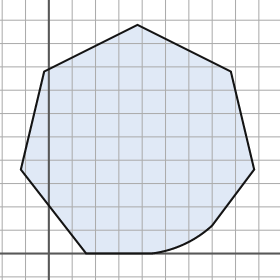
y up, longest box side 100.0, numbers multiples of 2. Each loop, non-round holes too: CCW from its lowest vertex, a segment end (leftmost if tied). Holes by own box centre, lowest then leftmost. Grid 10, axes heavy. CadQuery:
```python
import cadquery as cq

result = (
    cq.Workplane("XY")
    .moveTo(16.0, 0.0)
    .lineTo(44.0, 0.0)
    .threePointArc((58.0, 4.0), (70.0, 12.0))
    .lineTo(88.0, 36.0)
    .lineTo(78.0, 78.0)
    .lineTo(38.0, 98.0)
    .lineTo(-2.0, 78.0)
    .lineTo(-12.0, 36.0)
    .close()
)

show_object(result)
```